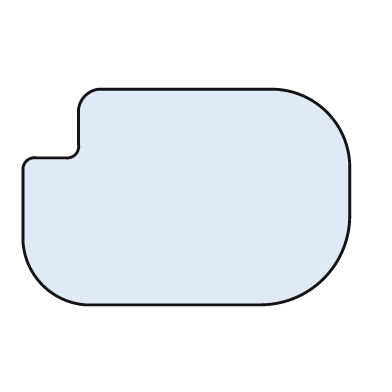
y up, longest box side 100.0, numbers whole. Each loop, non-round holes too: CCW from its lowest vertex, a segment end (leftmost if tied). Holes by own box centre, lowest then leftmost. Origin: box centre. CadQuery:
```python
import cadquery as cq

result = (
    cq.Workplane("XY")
    .moveTo(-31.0, -33.0)
    .lineTo(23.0, -33.0)
    .threePointArc((42.0, -25.0), (50.0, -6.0))
    .lineTo(50.0, 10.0)
    .threePointArc((43.0, 26.0), (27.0, 33.0))
    .lineTo(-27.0, 33.0)
    .threePointArc((-31.0, 31.0), (-33.0, 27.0))
    .lineTo(-33.0, 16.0)
    .threePointArc((-34.0, 13.0), (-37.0, 12.0))
    .lineTo(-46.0, 12.0)
    .threePointArc((-49.0, 11.0), (-50.0, 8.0))
    .lineTo(-50.0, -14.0)
    .threePointArc((-44.0, -27.0), (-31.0, -33.0))
    .close()
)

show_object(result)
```